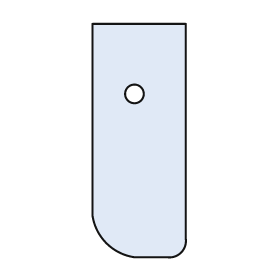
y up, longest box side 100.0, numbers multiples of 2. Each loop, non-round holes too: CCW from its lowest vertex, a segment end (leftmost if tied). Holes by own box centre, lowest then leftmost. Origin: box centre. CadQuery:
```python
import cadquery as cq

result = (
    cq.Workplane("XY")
    .moveTo(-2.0, -50.0)
    .lineTo(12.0, -50.0)
    .threePointArc((18.0, -48.0), (20.0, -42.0))
    .lineTo(20.0, 50.0)
    .lineTo(-20.0, 50.0)
    .lineTo(-20.0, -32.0)
    .threePointArc((-14.0, -44.0), (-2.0, -50.0))
    .close()
    .moveTo(-2.0, 20.0)
    .circle(4.0)
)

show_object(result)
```